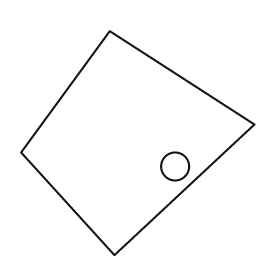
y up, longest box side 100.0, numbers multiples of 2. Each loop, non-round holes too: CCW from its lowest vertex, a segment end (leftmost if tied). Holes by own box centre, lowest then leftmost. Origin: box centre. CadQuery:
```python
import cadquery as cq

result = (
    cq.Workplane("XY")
    .moveTo(-10.0, -48.0)
    .lineTo(50.0, 8.0)
    .lineTo(-12.0, 48.0)
    .lineTo(-50.0, -4.0)
    .close()
    .moveTo(16.0, -10.0)
    .circle(6.0)
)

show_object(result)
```